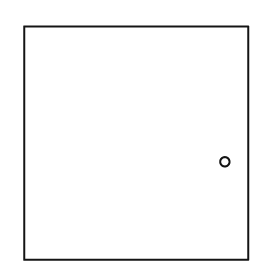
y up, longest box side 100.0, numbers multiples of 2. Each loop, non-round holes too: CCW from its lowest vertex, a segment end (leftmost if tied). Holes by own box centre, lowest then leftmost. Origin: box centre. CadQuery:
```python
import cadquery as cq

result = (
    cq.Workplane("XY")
    .moveTo(-48.0, -50.0)
    .lineTo(48.0, -50.0)
    .lineTo(48.0, 50.0)
    .lineTo(-48.0, 50.0)
    .close()
    .moveTo(38.0, -8.0)
    .circle(2.0)
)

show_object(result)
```